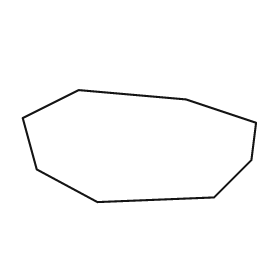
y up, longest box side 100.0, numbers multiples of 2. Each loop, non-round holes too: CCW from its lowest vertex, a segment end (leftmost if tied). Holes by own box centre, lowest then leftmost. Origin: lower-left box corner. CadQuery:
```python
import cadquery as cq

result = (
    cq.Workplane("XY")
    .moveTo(32.0, 0.0)
    .lineTo(82.0, 2.0)
    .lineTo(98.0, 18.0)
    .lineTo(100.0, 34.0)
    .lineTo(70.0, 44.0)
    .lineTo(24.0, 48.0)
    .lineTo(0.0, 36.0)
    .lineTo(6.0, 14.0)
    .close()
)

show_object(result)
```